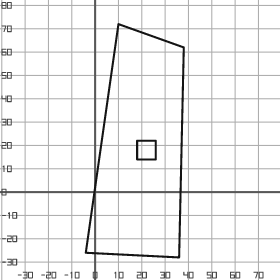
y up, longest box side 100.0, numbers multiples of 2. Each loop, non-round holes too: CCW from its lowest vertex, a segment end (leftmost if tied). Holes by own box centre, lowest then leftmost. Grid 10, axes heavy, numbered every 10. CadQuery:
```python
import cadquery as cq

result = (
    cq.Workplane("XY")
    .moveTo(36.0, -28.0)
    .lineTo(38.0, 62.0)
    .lineTo(10.0, 72.0)
    .lineTo(-4.0, -26.0)
    .close()
    .moveTo(18.0, 14.0)
    .lineTo(26.0, 14.0)
    .lineTo(26.0, 22.0)
    .lineTo(18.0, 22.0)
    .close()
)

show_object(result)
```